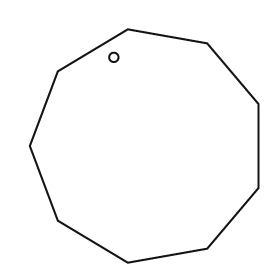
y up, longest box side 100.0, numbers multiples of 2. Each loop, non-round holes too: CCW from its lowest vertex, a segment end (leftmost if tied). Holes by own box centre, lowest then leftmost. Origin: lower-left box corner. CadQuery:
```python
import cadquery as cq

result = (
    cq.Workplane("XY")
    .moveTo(42.0, 0.0)
    .lineTo(76.0, 6.0)
    .lineTo(98.0, 32.0)
    .lineTo(98.0, 68.0)
    .lineTo(76.0, 94.0)
    .lineTo(42.0, 100.0)
    .lineTo(12.0, 82.0)
    .lineTo(0.0, 50.0)
    .lineTo(12.0, 18.0)
    .close()
    .moveTo(36.0, 88.0)
    .circle(2.0)
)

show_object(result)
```